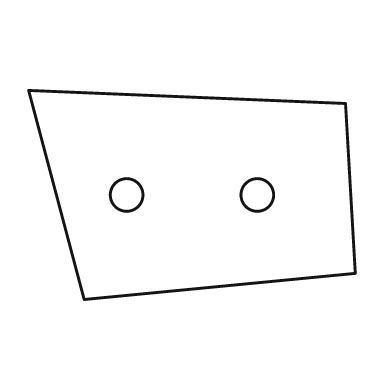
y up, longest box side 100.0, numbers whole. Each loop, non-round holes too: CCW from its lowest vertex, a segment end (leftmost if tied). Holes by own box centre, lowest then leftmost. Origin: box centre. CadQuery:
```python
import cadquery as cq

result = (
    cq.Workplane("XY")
    .moveTo(-33.0, -32.0)
    .lineTo(50.0, -24.0)
    .lineTo(47.0, 28.0)
    .lineTo(-50.0, 32.0)
    .close()
    .moveTo(-20.0, 0.0)
    .circle(5.0)
    .moveTo(20.0, 0.0)
    .circle(5.0)
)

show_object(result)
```